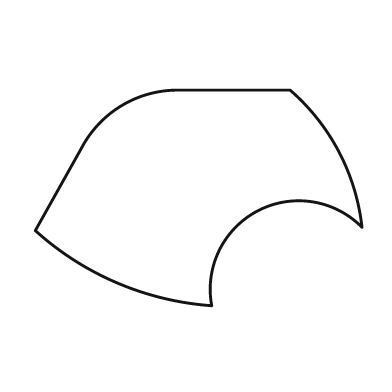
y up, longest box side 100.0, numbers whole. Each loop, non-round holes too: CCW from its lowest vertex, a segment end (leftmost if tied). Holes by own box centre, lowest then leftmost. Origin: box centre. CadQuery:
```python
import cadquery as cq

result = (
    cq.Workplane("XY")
    .moveTo(4.0, -33.0)
    .threePointArc((18.0, -4.0), (50.0, -9.0))
    .threePointArc((43.0, 14.0), (28.0, 33.0))
    .lineTo(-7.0, 33.0)
    .threePointArc((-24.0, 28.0), (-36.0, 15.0))
    .lineTo(-50.0, -10.0)
    .threePointArc((-25.0, -26.0), (4.0, -33.0))
    .close()
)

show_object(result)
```